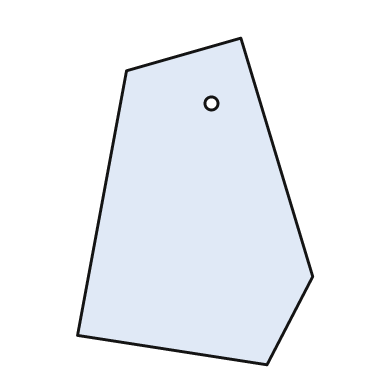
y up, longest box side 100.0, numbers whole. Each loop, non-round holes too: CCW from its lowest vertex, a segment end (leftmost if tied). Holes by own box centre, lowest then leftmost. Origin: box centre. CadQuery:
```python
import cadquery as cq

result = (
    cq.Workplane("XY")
    .moveTo(22.0, -50.0)
    .lineTo(36.0, -23.0)
    .lineTo(14.0, 50.0)
    .lineTo(-21.0, 40.0)
    .lineTo(-36.0, -41.0)
    .close()
    .moveTo(5.0, 30.0)
    .circle(2.0)
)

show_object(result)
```